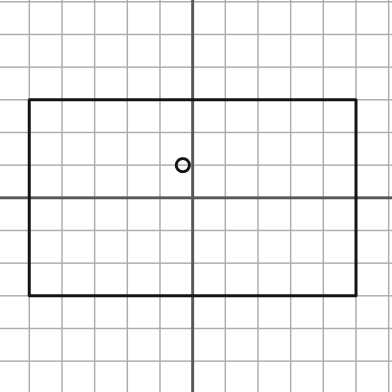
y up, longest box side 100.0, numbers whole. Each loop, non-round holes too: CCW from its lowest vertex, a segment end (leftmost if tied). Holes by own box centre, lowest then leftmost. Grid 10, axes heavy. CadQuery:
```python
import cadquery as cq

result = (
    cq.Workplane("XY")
    .moveTo(-50.0, -30.0)
    .lineTo(50.0, -30.0)
    .lineTo(50.0, 30.0)
    .lineTo(-50.0, 30.0)
    .close()
    .moveTo(-3.0, 10.0)
    .circle(2.0)
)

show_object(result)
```